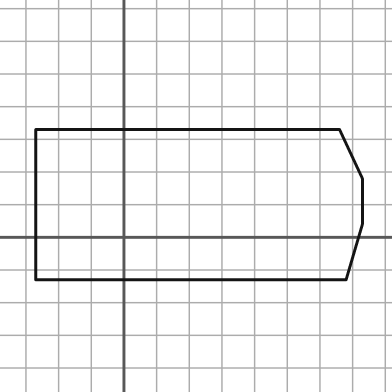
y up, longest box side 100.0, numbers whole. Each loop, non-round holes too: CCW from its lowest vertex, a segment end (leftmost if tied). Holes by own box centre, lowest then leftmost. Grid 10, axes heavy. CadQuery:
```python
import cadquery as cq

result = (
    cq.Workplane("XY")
    .moveTo(-27.0, -13.0)
    .lineTo(68.0, -13.0)
    .lineTo(73.0, 4.0)
    .lineTo(73.0, 18.0)
    .lineTo(66.0, 33.0)
    .lineTo(-27.0, 33.0)
    .close()
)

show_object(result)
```